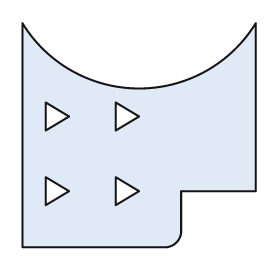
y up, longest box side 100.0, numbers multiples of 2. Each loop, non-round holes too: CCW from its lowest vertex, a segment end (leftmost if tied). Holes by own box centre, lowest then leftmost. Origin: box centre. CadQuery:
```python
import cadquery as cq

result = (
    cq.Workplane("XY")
    .moveTo(-50.0, -48.0)
    .lineTo(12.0, -48.0)
    .threePointArc((16.0, -46.0), (18.0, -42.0))
    .lineTo(18.0, -24.0)
    .lineTo(50.0, -24.0)
    .lineTo(50.0, 48.0)
    .threePointArc((0.0, 20.0), (-50.0, 48.0))
    .close()
    .moveTo(-40.0, -30.0)
    .lineTo(-30.0, -24.0)
    .lineTo(-40.0, -18.0)
    .close()
    .moveTo(-10.0, -30.0)
    .lineTo(0.0, -24.0)
    .lineTo(-10.0, -18.0)
    .close()
    .moveTo(-40.0, 2.0)
    .lineTo(-30.0, 8.0)
    .lineTo(-40.0, 14.0)
    .close()
    .moveTo(-10.0, 2.0)
    .lineTo(0.0, 8.0)
    .lineTo(-10.0, 14.0)
    .close()
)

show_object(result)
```